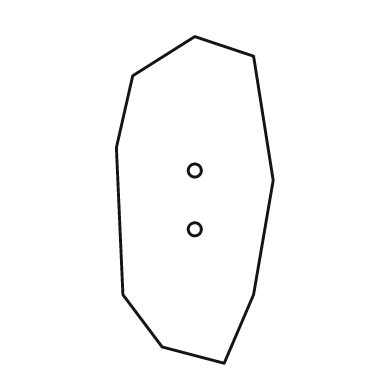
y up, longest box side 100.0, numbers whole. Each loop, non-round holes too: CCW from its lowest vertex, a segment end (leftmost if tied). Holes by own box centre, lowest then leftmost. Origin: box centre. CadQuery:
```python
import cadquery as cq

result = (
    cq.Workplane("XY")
    .moveTo(9.0, -50.0)
    .lineTo(18.0, -29.0)
    .lineTo(24.0, 6.0)
    .lineTo(18.0, 44.0)
    .lineTo(0.0, 50.0)
    .lineTo(-19.0, 38.0)
    .lineTo(-24.0, 16.0)
    .lineTo(-22.0, -29.0)
    .lineTo(-10.0, -45.0)
    .close()
    .moveTo(0.0, -9.0)
    .circle(2.0)
    .moveTo(0.0, 9.0)
    .circle(2.0)
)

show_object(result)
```